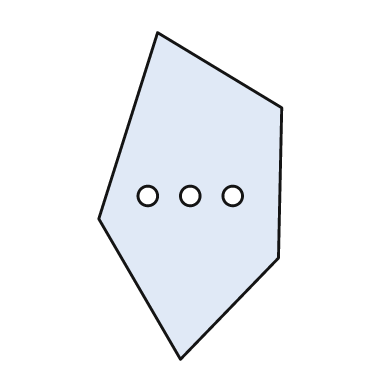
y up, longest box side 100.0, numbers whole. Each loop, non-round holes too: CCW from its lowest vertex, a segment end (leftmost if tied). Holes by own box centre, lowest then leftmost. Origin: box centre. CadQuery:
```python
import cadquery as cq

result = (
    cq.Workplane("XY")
    .moveTo(-3.0, -50.0)
    .lineTo(27.0, -19.0)
    .lineTo(28.0, 27.0)
    .lineTo(-10.0, 50.0)
    .lineTo(-28.0, -7.0)
    .close()
    .moveTo(-13.0, 0.0)
    .circle(3.0)
    .moveTo(0.0, 0.0)
    .circle(3.0)
    .moveTo(13.0, 0.0)
    .circle(3.0)
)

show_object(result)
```